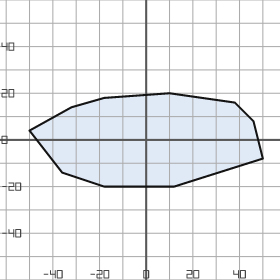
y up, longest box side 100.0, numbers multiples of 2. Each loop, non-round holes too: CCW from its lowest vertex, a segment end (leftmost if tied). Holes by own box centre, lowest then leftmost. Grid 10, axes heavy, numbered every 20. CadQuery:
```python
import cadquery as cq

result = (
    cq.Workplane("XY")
    .moveTo(-18.0, -20.0)
    .lineTo(12.0, -20.0)
    .lineTo(50.0, -8.0)
    .lineTo(46.0, 8.0)
    .lineTo(38.0, 16.0)
    .lineTo(10.0, 20.0)
    .lineTo(-18.0, 18.0)
    .lineTo(-32.0, 14.0)
    .lineTo(-50.0, 4.0)
    .lineTo(-36.0, -14.0)
    .close()
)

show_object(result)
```